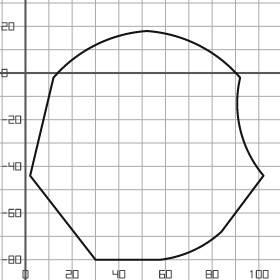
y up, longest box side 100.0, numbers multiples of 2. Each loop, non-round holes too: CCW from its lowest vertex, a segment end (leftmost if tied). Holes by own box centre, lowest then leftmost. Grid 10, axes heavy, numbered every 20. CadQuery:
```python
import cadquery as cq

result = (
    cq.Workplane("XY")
    .moveTo(30.0, -80.0)
    .lineTo(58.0, -80.0)
    .threePointArc((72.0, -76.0), (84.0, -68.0))
    .lineTo(102.0, -44.0)
    .threePointArc((92.0, -24.0), (92.0, -2.0))
    .threePointArc((74.0, 12.0), (52.0, 18.0))
    .threePointArc((30.0, 12.0), (12.0, -2.0))
    .lineTo(2.0, -44.0)
    .close()
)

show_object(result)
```